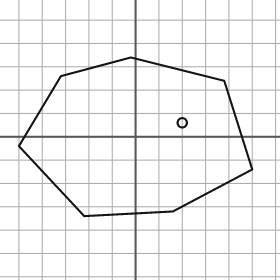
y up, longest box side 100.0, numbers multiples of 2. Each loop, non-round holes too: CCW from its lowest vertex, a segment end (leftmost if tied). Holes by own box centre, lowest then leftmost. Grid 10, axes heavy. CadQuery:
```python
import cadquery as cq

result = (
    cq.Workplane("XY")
    .moveTo(-22.0, -34.0)
    .lineTo(16.0, -32.0)
    .lineTo(50.0, -14.0)
    .lineTo(38.0, 24.0)
    .lineTo(-2.0, 34.0)
    .lineTo(-32.0, 26.0)
    .lineTo(-50.0, -4.0)
    .close()
    .moveTo(20.0, 6.0)
    .circle(2.0)
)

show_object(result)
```